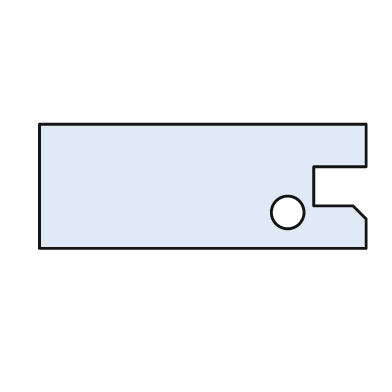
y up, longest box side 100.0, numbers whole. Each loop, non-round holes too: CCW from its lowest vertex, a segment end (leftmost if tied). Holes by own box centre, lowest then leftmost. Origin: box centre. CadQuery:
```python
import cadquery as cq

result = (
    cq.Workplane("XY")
    .moveTo(-50.0, -19.0)
    .lineTo(50.0, -19.0)
    .lineTo(50.0, -10.0)
    .lineTo(46.0, -6.0)
    .lineTo(34.0, -6.0)
    .lineTo(34.0, 6.0)
    .lineTo(50.0, 6.0)
    .lineTo(50.0, 19.0)
    .lineTo(-50.0, 19.0)
    .close()
    .moveTo(26.0, -8.0)
    .circle(5.0)
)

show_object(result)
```